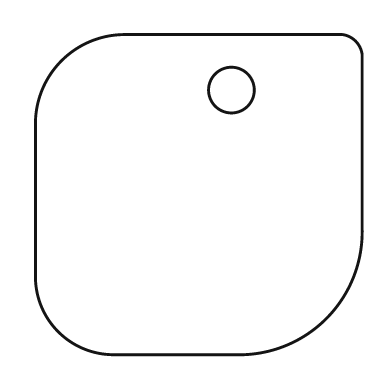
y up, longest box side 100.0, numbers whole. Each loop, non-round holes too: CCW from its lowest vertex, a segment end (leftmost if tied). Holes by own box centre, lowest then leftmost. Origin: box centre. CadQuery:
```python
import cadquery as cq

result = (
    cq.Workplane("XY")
    .moveTo(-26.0, -49.0)
    .lineTo(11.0, -49.0)
    .threePointArc((39.0, -38.0), (50.0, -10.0))
    .lineTo(50.0, 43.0)
    .threePointArc((48.0, 47.0), (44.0, 49.0))
    .lineTo(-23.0, 49.0)
    .threePointArc((-42.0, 41.0), (-50.0, 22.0))
    .lineTo(-50.0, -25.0)
    .threePointArc((-43.0, -42.0), (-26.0, -49.0))
    .close()
    .moveTo(10.0, 32.0)
    .circle(7.0)
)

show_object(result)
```